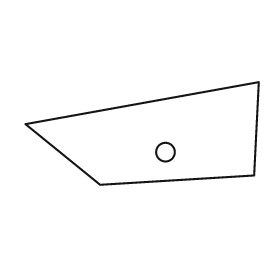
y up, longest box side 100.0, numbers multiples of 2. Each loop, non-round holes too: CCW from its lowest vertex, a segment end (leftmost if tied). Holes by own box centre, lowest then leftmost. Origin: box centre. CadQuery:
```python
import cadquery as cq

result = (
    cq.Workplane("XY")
    .moveTo(-18.0, -22.0)
    .lineTo(48.0, -18.0)
    .lineTo(50.0, 22.0)
    .lineTo(-50.0, 4.0)
    .close()
    .moveTo(10.0, -8.0)
    .circle(4.0)
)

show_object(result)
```